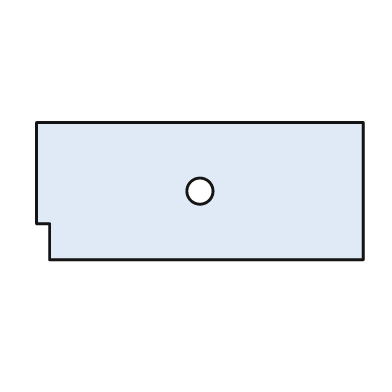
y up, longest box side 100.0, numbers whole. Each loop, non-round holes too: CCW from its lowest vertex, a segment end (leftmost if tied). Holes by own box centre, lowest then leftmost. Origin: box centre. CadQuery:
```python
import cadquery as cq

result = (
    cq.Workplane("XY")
    .moveTo(-46.0, -21.0)
    .lineTo(50.0, -21.0)
    .lineTo(50.0, 21.0)
    .lineTo(-50.0, 21.0)
    .lineTo(-50.0, -10.0)
    .lineTo(-46.0, -10.0)
    .close()
    .moveTo(0.0, 0.0)
    .circle(4.0)
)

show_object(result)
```